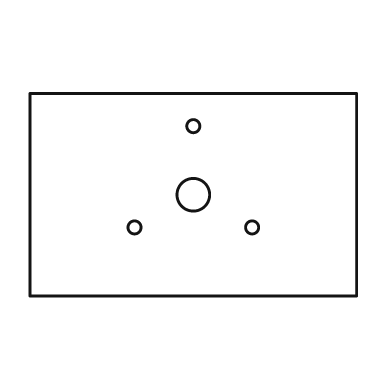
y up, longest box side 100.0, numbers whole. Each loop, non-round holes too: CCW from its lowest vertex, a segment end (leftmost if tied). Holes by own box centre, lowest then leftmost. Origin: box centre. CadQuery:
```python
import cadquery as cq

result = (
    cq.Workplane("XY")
    .moveTo(-50.0, -31.0)
    .lineTo(50.0, -31.0)
    .lineTo(50.0, 31.0)
    .lineTo(-50.0, 31.0)
    .close()
    .moveTo(-18.0, -10.0)
    .circle(2.0)
    .moveTo(18.0, -10.0)
    .circle(2.0)
    .moveTo(0.0, 0.0)
    .circle(5.0)
    .moveTo(0.0, 21.0)
    .circle(2.0)
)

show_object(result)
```